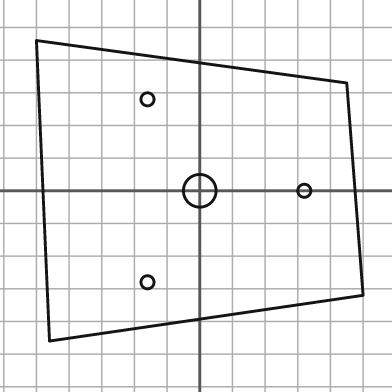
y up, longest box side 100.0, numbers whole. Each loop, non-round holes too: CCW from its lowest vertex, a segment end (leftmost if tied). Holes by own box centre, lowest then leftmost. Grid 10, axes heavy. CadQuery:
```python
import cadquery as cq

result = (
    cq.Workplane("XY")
    .moveTo(-46.0, -46.0)
    .lineTo(50.0, -32.0)
    .lineTo(45.0, 33.0)
    .lineTo(-50.0, 46.0)
    .close()
    .moveTo(-16.0, -28.0)
    .circle(2.0)
    .moveTo(0.0, 0.0)
    .circle(5.0)
    .moveTo(32.0, 0.0)
    .circle(2.0)
    .moveTo(-16.0, 28.0)
    .circle(2.0)
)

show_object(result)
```